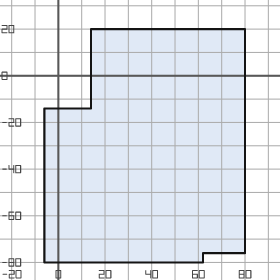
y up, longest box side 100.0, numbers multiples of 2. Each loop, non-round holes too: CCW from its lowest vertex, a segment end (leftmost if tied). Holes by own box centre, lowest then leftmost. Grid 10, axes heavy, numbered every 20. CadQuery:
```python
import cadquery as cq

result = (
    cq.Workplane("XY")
    .moveTo(-6.0, -80.0)
    .lineTo(62.0, -80.0)
    .lineTo(62.0, -76.0)
    .lineTo(80.0, -76.0)
    .lineTo(80.0, 20.0)
    .lineTo(14.0, 20.0)
    .lineTo(14.0, -14.0)
    .lineTo(-6.0, -14.0)
    .close()
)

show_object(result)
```